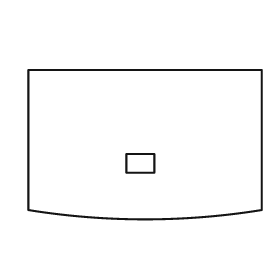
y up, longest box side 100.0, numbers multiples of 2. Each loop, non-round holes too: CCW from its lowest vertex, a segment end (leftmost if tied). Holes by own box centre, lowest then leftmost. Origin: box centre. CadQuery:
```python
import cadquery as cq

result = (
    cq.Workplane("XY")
    .moveTo(-50.0, -28.0)
    .threePointArc((0.0, -32.0), (50.0, -28.0))
    .lineTo(50.0, 32.0)
    .lineTo(-50.0, 32.0)
    .close()
    .moveTo(-8.0, -12.0)
    .lineTo(4.0, -12.0)
    .lineTo(4.0, -4.0)
    .lineTo(-8.0, -4.0)
    .close()
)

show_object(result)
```